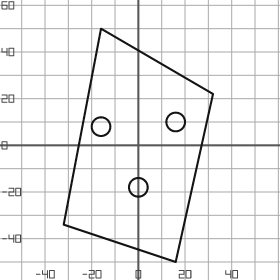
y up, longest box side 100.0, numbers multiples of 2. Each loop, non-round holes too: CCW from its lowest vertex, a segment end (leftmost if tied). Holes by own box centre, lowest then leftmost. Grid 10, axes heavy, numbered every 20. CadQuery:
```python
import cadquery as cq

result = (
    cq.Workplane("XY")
    .moveTo(16.0, -50.0)
    .lineTo(32.0, 22.0)
    .lineTo(-16.0, 50.0)
    .lineTo(-32.0, -34.0)
    .close()
    .moveTo(0.0, -18.0)
    .circle(4.0)
    .moveTo(-16.0, 8.0)
    .circle(4.0)
    .moveTo(16.0, 10.0)
    .circle(4.0)
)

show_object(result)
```